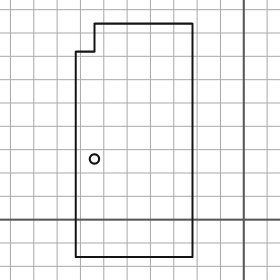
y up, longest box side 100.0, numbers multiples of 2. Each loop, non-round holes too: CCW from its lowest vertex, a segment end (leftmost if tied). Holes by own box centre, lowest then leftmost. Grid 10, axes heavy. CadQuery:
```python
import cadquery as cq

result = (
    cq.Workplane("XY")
    .moveTo(-72.0, -16.0)
    .lineTo(-22.0, -16.0)
    .lineTo(-22.0, 84.0)
    .lineTo(-64.0, 84.0)
    .lineTo(-64.0, 72.0)
    .lineTo(-72.0, 72.0)
    .close()
    .moveTo(-64.0, 26.0)
    .circle(2.0)
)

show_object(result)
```